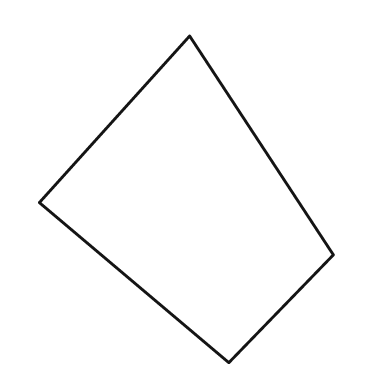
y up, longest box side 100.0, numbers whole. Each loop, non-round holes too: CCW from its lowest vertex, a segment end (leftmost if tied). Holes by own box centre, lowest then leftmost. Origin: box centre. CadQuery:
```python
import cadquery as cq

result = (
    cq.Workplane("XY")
    .moveTo(13.0, -50.0)
    .lineTo(45.0, -17.0)
    .lineTo(1.0, 50.0)
    .lineTo(-45.0, -1.0)
    .close()
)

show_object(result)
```